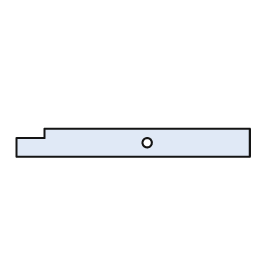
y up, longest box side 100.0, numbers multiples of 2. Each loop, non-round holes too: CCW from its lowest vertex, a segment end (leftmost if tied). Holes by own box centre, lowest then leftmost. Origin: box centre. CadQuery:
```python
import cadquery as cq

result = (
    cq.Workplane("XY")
    .moveTo(-50.0, -6.0)
    .lineTo(50.0, -6.0)
    .lineTo(50.0, 6.0)
    .lineTo(-38.0, 6.0)
    .lineTo(-38.0, 2.0)
    .lineTo(-50.0, 2.0)
    .close()
    .moveTo(6.0, 0.0)
    .circle(2.0)
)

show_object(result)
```